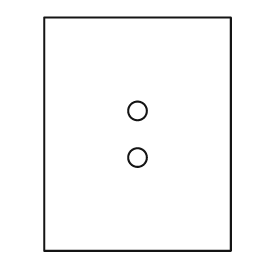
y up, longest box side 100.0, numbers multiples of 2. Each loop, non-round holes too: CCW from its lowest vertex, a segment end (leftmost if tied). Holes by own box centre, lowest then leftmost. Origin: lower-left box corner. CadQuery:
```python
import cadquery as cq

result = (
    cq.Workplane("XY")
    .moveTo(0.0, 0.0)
    .lineTo(80.0, 0.0)
    .lineTo(80.0, 100.0)
    .lineTo(0.0, 100.0)
    .close()
    .moveTo(40.0, 40.0)
    .circle(4.0)
    .moveTo(40.0, 60.0)
    .circle(4.0)
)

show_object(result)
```